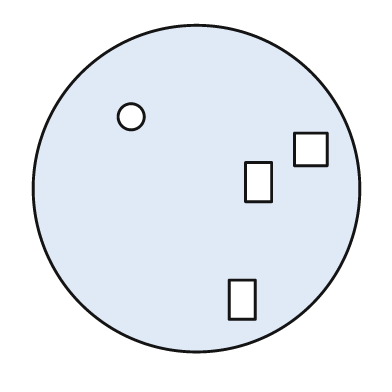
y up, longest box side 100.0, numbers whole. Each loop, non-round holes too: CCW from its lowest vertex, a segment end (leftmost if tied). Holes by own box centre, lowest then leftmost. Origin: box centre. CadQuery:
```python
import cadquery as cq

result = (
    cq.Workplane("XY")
    .moveTo(0.0, 0.0)
    .circle(50.0)
    .moveTo(10.0, -40.0)
    .lineTo(18.0, -40.0)
    .lineTo(18.0, -28.0)
    .lineTo(10.0, -28.0)
    .close()
    .moveTo(15.0, -4.0)
    .lineTo(23.0, -4.0)
    .lineTo(23.0, 8.0)
    .lineTo(15.0, 8.0)
    .close()
    .moveTo(30.0, 7.0)
    .lineTo(40.0, 7.0)
    .lineTo(40.0, 17.0)
    .lineTo(30.0, 17.0)
    .close()
    .moveTo(-20.0, 22.0)
    .circle(4.0)
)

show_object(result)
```